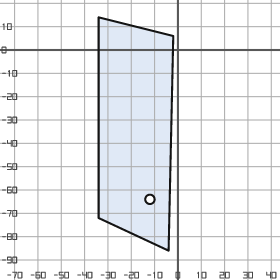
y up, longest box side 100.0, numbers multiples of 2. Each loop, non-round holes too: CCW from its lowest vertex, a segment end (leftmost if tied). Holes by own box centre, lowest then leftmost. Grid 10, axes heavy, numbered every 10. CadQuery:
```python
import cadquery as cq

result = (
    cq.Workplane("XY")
    .moveTo(-4.0, -86.0)
    .lineTo(-2.0, 6.0)
    .lineTo(-34.0, 14.0)
    .lineTo(-34.0, -72.0)
    .close()
    .moveTo(-12.0, -64.0)
    .circle(2.0)
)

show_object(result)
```